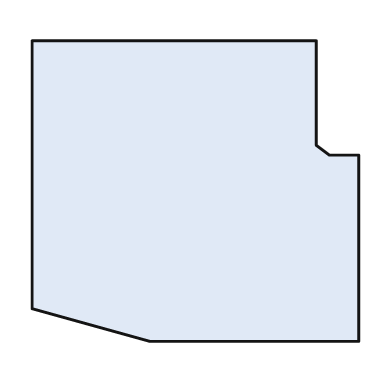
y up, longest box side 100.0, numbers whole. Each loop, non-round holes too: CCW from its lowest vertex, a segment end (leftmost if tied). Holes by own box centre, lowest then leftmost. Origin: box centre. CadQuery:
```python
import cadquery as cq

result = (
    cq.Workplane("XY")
    .moveTo(-14.0, -46.0)
    .lineTo(50.0, -46.0)
    .lineTo(50.0, 11.0)
    .lineTo(41.0, 11.0)
    .lineTo(37.0, 14.0)
    .lineTo(37.0, 46.0)
    .lineTo(-50.0, 46.0)
    .lineTo(-50.0, -36.0)
    .close()
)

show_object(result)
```